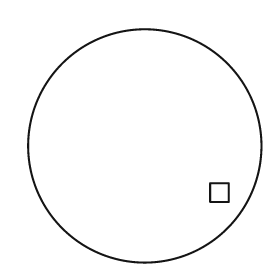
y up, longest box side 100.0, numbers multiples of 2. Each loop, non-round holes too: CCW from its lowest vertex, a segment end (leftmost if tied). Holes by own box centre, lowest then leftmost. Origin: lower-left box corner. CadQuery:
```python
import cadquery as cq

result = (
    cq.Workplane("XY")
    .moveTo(50.0, 50.0)
    .circle(50.0)
    .moveTo(78.0, 26.0)
    .lineTo(86.0, 26.0)
    .lineTo(86.0, 34.0)
    .lineTo(78.0, 34.0)
    .close()
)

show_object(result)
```